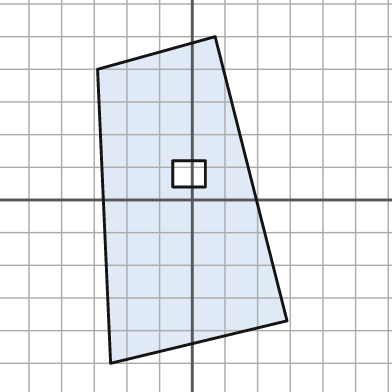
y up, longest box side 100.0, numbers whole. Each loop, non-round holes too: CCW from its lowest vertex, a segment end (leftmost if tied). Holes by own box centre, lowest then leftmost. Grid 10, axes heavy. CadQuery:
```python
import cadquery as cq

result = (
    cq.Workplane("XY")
    .moveTo(-25.0, -50.0)
    .lineTo(29.0, -37.0)
    .lineTo(7.0, 50.0)
    .lineTo(-29.0, 40.0)
    .close()
    .moveTo(-6.0, 4.0)
    .lineTo(4.0, 4.0)
    .lineTo(4.0, 12.0)
    .lineTo(-6.0, 12.0)
    .close()
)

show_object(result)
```